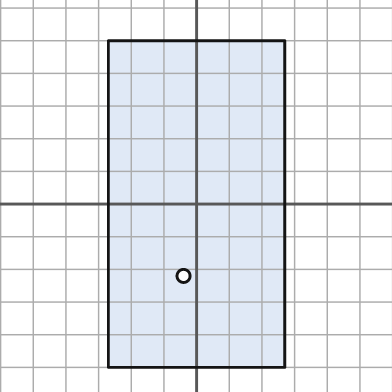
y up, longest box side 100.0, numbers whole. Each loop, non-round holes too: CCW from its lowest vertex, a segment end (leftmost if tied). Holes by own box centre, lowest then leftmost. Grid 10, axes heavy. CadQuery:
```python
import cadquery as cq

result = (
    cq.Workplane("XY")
    .moveTo(-27.0, -50.0)
    .lineTo(27.0, -50.0)
    .lineTo(27.0, 50.0)
    .lineTo(-27.0, 50.0)
    .close()
    .moveTo(-4.0, -22.0)
    .circle(2.0)
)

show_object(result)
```